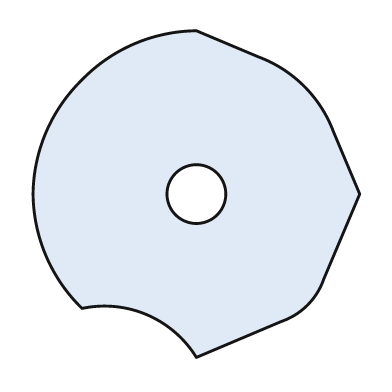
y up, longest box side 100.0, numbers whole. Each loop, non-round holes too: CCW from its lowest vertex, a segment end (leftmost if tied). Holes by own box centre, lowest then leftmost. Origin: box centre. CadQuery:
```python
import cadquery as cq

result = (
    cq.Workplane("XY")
    .moveTo(0.0, -50.0)
    .lineTo(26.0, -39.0)
    .threePointArc((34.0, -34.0), (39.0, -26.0))
    .lineTo(50.0, 0.0)
    .lineTo(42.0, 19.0)
    .threePointArc((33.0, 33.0), (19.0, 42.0))
    .lineTo(0.0, 50.0)
    .threePointArc((-19.0, 46.0), (-35.0, 35.0))
    .threePointArc((-46.0, 19.0), (-50.0, 0.0))
    .threePointArc((-46.0, -19.0), (-35.0, -35.0))
    .threePointArc((-15.0, -37.0), (0.0, -50.0))
    .close()
    .moveTo(0.0, 0.0)
    .circle(9.0)
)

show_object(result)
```